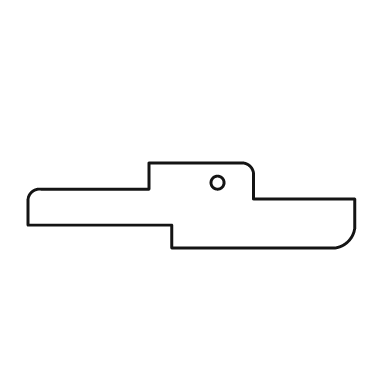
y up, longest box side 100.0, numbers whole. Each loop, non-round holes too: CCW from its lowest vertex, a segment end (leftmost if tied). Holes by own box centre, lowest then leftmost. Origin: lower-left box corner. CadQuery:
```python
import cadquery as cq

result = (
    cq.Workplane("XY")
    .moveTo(44.0, 0.0)
    .lineTo(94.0, 0.0)
    .threePointArc((98.0, 2.0), (100.0, 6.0))
    .lineTo(100.0, 15.0)
    .lineTo(69.0, 15.0)
    .lineTo(69.0, 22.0)
    .threePointArc((68.0, 25.0), (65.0, 26.0))
    .lineTo(37.0, 26.0)
    .lineTo(37.0, 18.0)
    .lineTo(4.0, 18.0)
    .threePointArc((1.0, 17.0), (0.0, 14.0))
    .lineTo(0.0, 7.0)
    .lineTo(44.0, 7.0)
    .close()
    .moveTo(58.0, 20.0)
    .circle(2.0)
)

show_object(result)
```